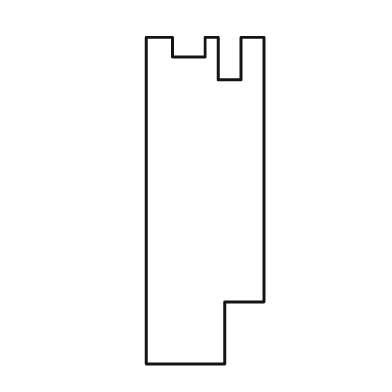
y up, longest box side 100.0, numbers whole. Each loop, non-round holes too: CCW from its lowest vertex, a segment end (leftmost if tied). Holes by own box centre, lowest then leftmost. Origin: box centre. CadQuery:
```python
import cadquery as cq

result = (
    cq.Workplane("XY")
    .moveTo(-18.0, -50.0)
    .lineTo(6.0, -50.0)
    .lineTo(6.0, -31.0)
    .lineTo(18.0, -31.0)
    .lineTo(18.0, 50.0)
    .lineTo(11.0, 50.0)
    .lineTo(11.0, 37.0)
    .lineTo(4.0, 37.0)
    .lineTo(4.0, 50.0)
    .lineTo(0.0, 50.0)
    .lineTo(0.0, 44.0)
    .lineTo(-10.0, 44.0)
    .lineTo(-10.0, 50.0)
    .lineTo(-18.0, 50.0)
    .close()
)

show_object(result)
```